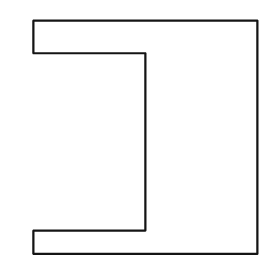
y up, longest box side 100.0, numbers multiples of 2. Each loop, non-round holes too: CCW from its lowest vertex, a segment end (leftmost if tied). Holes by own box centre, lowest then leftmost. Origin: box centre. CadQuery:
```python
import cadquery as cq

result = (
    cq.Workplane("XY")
    .moveTo(-48.0, -50.0)
    .lineTo(48.0, -50.0)
    .lineTo(48.0, 50.0)
    .lineTo(-48.0, 50.0)
    .lineTo(-48.0, 36.0)
    .lineTo(0.0, 36.0)
    .lineTo(0.0, -40.0)
    .lineTo(-48.0, -40.0)
    .close()
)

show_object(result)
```